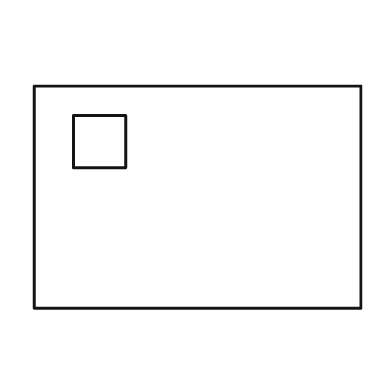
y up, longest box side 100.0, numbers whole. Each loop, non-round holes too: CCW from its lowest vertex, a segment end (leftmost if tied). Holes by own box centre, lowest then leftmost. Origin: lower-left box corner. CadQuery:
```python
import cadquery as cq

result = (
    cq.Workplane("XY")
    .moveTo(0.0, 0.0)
    .lineTo(100.0, 0.0)
    .lineTo(100.0, 68.0)
    .lineTo(0.0, 68.0)
    .close()
    .moveTo(12.0, 43.0)
    .lineTo(28.0, 43.0)
    .lineTo(28.0, 59.0)
    .lineTo(12.0, 59.0)
    .close()
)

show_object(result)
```